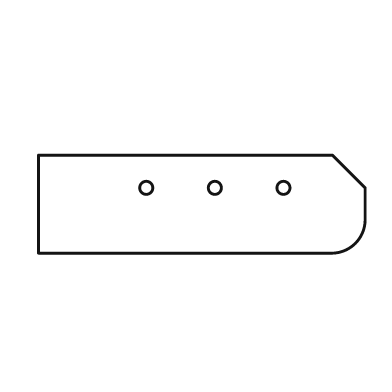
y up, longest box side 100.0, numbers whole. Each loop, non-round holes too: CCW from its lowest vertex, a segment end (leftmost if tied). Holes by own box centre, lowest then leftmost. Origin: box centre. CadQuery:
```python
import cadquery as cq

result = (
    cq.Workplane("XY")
    .moveTo(-50.0, -15.0)
    .lineTo(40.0, -15.0)
    .threePointArc((47.0, -12.0), (50.0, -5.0))
    .lineTo(50.0, 5.0)
    .lineTo(40.0, 15.0)
    .lineTo(-50.0, 15.0)
    .close()
    .moveTo(-17.0, 5.0)
    .circle(2.0)
    .moveTo(4.0, 5.0)
    .circle(2.0)
    .moveTo(25.0, 5.0)
    .circle(2.0)
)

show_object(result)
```